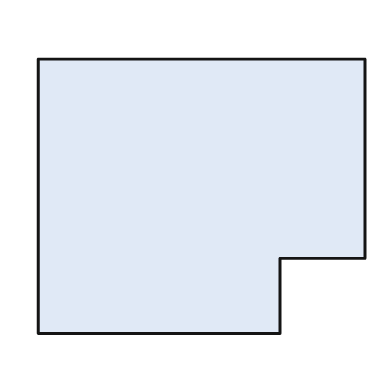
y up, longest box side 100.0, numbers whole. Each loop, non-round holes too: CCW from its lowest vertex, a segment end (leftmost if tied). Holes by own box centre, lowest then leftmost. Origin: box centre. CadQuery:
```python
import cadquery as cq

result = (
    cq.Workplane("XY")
    .moveTo(-50.0, -42.0)
    .lineTo(24.0, -42.0)
    .lineTo(24.0, -19.0)
    .lineTo(50.0, -19.0)
    .lineTo(50.0, 42.0)
    .lineTo(-50.0, 42.0)
    .close()
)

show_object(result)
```